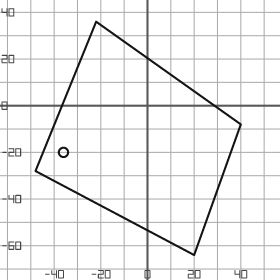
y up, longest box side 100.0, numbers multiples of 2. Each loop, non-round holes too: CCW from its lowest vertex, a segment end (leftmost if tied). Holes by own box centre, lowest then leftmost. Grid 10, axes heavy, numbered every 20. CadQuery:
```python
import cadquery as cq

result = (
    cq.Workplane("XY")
    .moveTo(20.0, -64.0)
    .lineTo(40.0, -8.0)
    .lineTo(-22.0, 36.0)
    .lineTo(-48.0, -28.0)
    .close()
    .moveTo(-36.0, -20.0)
    .circle(2.0)
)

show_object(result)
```